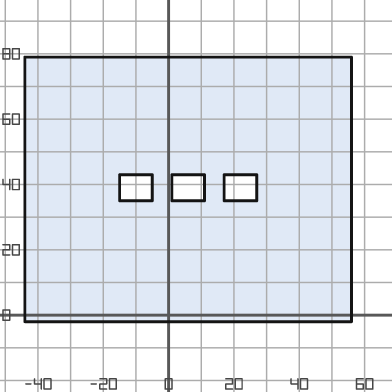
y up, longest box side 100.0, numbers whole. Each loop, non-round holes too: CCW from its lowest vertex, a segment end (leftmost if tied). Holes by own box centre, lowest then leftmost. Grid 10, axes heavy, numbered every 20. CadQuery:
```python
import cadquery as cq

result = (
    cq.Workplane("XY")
    .moveTo(-44.0, -2.0)
    .lineTo(56.0, -2.0)
    .lineTo(56.0, 79.0)
    .lineTo(-44.0, 79.0)
    .close()
    .moveTo(-15.0, 35.0)
    .lineTo(-5.0, 35.0)
    .lineTo(-5.0, 43.0)
    .lineTo(-15.0, 43.0)
    .close()
    .moveTo(1.0, 35.0)
    .lineTo(11.0, 35.0)
    .lineTo(11.0, 43.0)
    .lineTo(1.0, 43.0)
    .close()
    .moveTo(17.0, 35.0)
    .lineTo(27.0, 35.0)
    .lineTo(27.0, 43.0)
    .lineTo(17.0, 43.0)
    .close()
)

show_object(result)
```